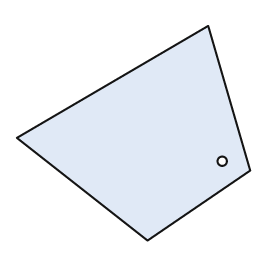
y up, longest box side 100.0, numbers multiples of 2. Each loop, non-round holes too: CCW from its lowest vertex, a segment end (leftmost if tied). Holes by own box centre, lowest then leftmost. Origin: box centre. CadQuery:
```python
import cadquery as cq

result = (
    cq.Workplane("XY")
    .moveTo(6.0, -46.0)
    .lineTo(50.0, -16.0)
    .lineTo(32.0, 46.0)
    .lineTo(-50.0, -2.0)
    .close()
    .moveTo(38.0, -12.0)
    .circle(2.0)
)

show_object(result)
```